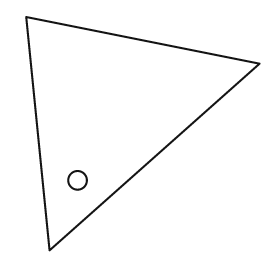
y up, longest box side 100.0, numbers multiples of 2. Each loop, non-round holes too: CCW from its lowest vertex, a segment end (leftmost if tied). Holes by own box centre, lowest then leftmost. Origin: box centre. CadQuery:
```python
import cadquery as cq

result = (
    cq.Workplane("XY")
    .moveTo(-40.0, -50.0)
    .lineTo(50.0, 30.0)
    .lineTo(-50.0, 50.0)
    .close()
    .moveTo(-28.0, -20.0)
    .circle(4.0)
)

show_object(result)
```